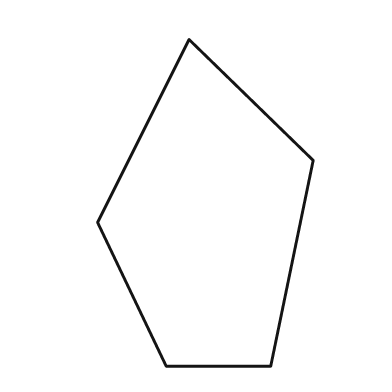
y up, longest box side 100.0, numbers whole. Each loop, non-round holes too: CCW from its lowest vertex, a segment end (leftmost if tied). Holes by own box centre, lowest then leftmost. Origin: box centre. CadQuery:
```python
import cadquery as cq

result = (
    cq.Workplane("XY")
    .moveTo(-12.0, -50.0)
    .lineTo(20.0, -50.0)
    .lineTo(33.0, 13.0)
    .lineTo(-5.0, 50.0)
    .lineTo(-33.0, -6.0)
    .close()
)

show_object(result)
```